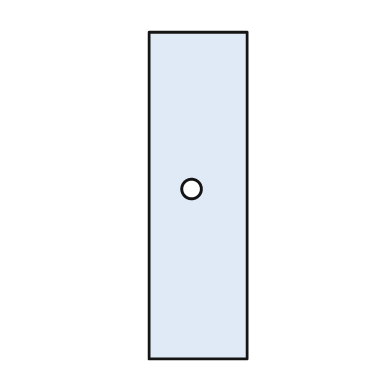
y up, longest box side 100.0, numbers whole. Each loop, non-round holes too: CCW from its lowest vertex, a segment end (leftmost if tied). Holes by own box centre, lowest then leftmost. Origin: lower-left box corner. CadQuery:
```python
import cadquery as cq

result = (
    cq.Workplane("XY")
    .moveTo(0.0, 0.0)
    .lineTo(30.0, 0.0)
    .lineTo(30.0, 100.0)
    .lineTo(0.0, 100.0)
    .close()
    .moveTo(13.0, 52.0)
    .circle(3.0)
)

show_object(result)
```